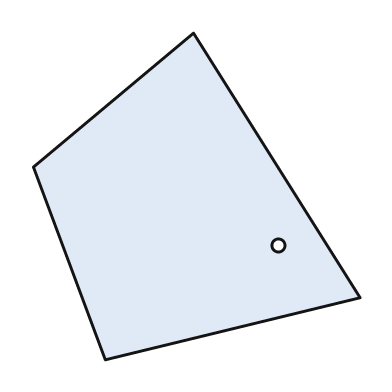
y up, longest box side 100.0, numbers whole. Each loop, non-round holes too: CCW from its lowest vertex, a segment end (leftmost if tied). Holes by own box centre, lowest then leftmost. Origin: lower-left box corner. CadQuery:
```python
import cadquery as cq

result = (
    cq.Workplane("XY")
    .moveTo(22.0, 0.0)
    .lineTo(100.0, 19.0)
    .lineTo(49.0, 100.0)
    .lineTo(0.0, 59.0)
    .close()
    .moveTo(75.0, 35.0)
    .circle(2.0)
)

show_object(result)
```